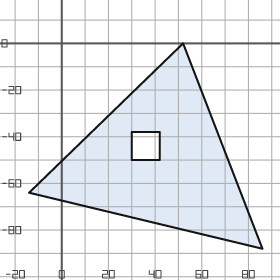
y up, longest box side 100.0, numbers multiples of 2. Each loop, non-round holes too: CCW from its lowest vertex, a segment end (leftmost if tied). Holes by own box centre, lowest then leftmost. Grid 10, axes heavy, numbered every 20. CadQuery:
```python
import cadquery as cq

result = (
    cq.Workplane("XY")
    .moveTo(86.0, -88.0)
    .lineTo(52.0, 0.0)
    .lineTo(-14.0, -64.0)
    .close()
    .moveTo(30.0, -50.0)
    .lineTo(42.0, -50.0)
    .lineTo(42.0, -38.0)
    .lineTo(30.0, -38.0)
    .close()
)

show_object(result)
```